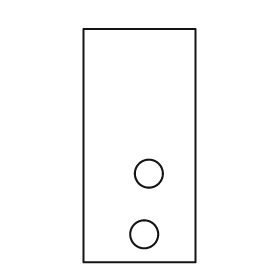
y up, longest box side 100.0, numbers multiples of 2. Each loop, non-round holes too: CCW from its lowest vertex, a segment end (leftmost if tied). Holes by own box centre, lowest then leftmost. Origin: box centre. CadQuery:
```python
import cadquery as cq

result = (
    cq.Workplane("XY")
    .moveTo(-24.0, -50.0)
    .lineTo(24.0, -50.0)
    .lineTo(24.0, 50.0)
    .lineTo(-24.0, 50.0)
    .close()
    .moveTo(2.0, -38.0)
    .circle(6.0)
    .moveTo(4.0, -12.0)
    .circle(6.0)
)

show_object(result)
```